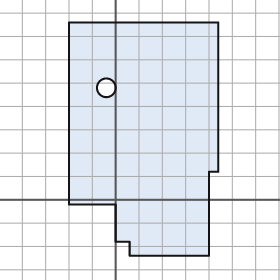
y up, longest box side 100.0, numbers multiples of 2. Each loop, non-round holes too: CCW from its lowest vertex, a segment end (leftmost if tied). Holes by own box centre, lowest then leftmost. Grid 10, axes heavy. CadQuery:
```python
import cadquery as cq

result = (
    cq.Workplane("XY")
    .moveTo(6.0, -24.0)
    .lineTo(40.0, -24.0)
    .lineTo(40.0, 12.0)
    .lineTo(44.0, 12.0)
    .lineTo(44.0, 76.0)
    .lineTo(-20.0, 76.0)
    .lineTo(-20.0, -2.0)
    .lineTo(0.0, -2.0)
    .lineTo(0.0, -18.0)
    .lineTo(6.0, -18.0)
    .close()
    .moveTo(-4.0, 48.0)
    .circle(4.0)
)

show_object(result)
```